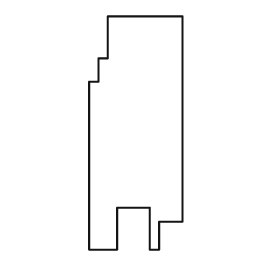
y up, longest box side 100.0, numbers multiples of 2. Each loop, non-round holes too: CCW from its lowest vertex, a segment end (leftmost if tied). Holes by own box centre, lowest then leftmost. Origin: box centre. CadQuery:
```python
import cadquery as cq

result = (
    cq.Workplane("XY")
    .moveTo(-20.0, -50.0)
    .lineTo(-8.0, -50.0)
    .lineTo(-8.0, -32.0)
    .lineTo(6.0, -32.0)
    .lineTo(6.0, -50.0)
    .lineTo(10.0, -50.0)
    .lineTo(10.0, -38.0)
    .lineTo(20.0, -38.0)
    .lineTo(20.0, 50.0)
    .lineTo(-12.0, 50.0)
    .lineTo(-12.0, 32.0)
    .lineTo(-16.0, 32.0)
    .lineTo(-16.0, 22.0)
    .lineTo(-20.0, 22.0)
    .close()
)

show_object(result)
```